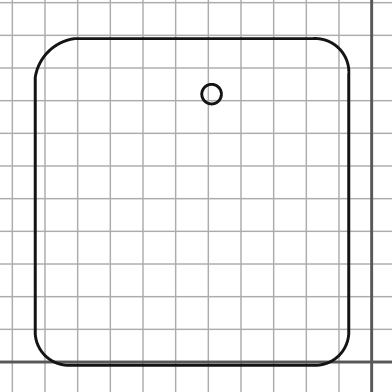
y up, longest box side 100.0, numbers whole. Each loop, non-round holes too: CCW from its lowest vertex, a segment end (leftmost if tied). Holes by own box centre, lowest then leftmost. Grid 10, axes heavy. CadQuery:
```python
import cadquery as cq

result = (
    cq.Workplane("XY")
    .moveTo(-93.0, -1.0)
    .lineTo(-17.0, -1.0)
    .threePointArc((-10.0, 2.0), (-7.0, 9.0))
    .lineTo(-7.0, 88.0)
    .threePointArc((-10.0, 96.0), (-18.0, 99.0))
    .lineTo(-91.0, 99.0)
    .threePointArc((-99.0, 95.0), (-103.0, 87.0))
    .lineTo(-103.0, 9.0)
    .threePointArc((-100.0, 2.0), (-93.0, -1.0))
    .close()
    .moveTo(-49.0, 82.0)
    .circle(3.0)
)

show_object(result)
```